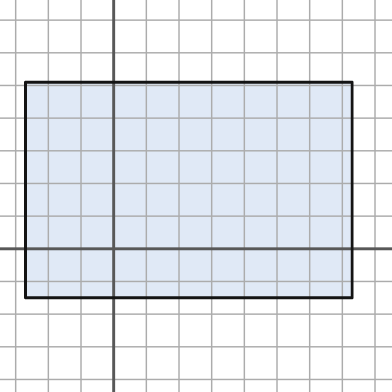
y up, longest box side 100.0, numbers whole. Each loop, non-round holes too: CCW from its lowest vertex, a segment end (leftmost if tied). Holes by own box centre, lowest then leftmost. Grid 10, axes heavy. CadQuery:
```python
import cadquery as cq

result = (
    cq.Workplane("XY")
    .moveTo(-27.0, -15.0)
    .lineTo(73.0, -15.0)
    .lineTo(73.0, 51.0)
    .lineTo(-27.0, 51.0)
    .close()
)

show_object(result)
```